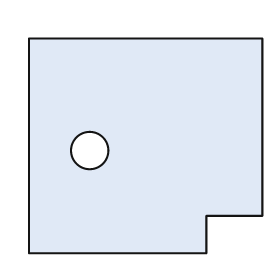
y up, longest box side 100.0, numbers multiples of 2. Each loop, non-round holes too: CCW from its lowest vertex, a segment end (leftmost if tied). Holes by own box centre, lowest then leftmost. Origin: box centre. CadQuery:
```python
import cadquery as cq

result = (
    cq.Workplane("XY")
    .moveTo(-50.0, -46.0)
    .lineTo(26.0, -46.0)
    .lineTo(26.0, -30.0)
    .lineTo(50.0, -30.0)
    .lineTo(50.0, 46.0)
    .lineTo(-50.0, 46.0)
    .close()
    .moveTo(-24.0, -2.0)
    .circle(8.0)
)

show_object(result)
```